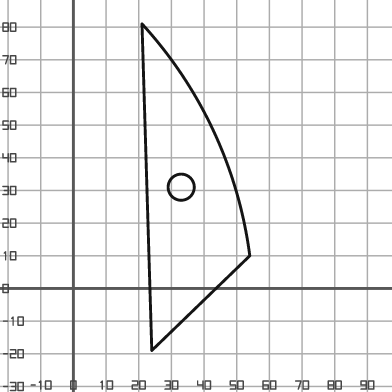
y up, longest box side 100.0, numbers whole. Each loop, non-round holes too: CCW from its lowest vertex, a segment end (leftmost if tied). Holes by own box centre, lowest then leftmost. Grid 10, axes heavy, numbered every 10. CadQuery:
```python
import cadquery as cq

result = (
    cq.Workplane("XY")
    .moveTo(24.0, -19.0)
    .lineTo(54.0, 10.0)
    .threePointArc((43.0, 48.0), (21.0, 81.0))
    .close()
    .moveTo(33.0, 31.0)
    .circle(4.0)
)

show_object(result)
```